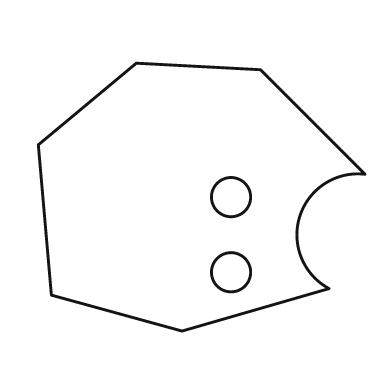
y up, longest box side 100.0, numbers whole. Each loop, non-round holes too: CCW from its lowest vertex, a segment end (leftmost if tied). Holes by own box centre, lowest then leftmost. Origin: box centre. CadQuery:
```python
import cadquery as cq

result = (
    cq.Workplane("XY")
    .moveTo(-6.0, -41.0)
    .lineTo(39.0, -28.0)
    .threePointArc((30.0, -6.0), (50.0, 7.0))
    .lineTo(18.0, 39.0)
    .lineTo(-20.0, 41.0)
    .lineTo(-50.0, 16.0)
    .lineTo(-46.0, -30.0)
    .close()
    .moveTo(9.0, -23.0)
    .circle(6.0)
    .moveTo(9.0, 0.0)
    .circle(6.0)
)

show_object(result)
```